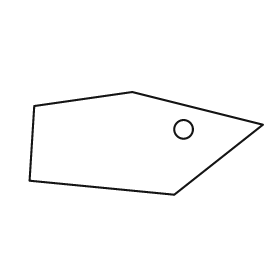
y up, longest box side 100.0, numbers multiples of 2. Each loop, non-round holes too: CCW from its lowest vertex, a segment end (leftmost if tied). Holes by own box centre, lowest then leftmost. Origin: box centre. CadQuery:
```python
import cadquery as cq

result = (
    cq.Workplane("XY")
    .moveTo(12.0, -22.0)
    .lineTo(50.0, 8.0)
    .lineTo(-6.0, 22.0)
    .lineTo(-48.0, 16.0)
    .lineTo(-50.0, -16.0)
    .close()
    .moveTo(16.0, 6.0)
    .circle(4.0)
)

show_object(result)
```